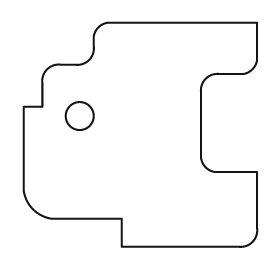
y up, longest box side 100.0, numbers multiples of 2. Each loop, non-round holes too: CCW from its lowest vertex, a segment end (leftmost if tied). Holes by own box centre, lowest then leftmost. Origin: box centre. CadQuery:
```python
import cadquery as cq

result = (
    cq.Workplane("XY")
    .moveTo(-8.0, -48.0)
    .lineTo(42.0, -48.0)
    .threePointArc((48.0, -46.0), (50.0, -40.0))
    .lineTo(50.0, -16.0)
    .lineTo(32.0, -16.0)
    .threePointArc((28.0, -14.0), (26.0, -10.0))
    .lineTo(26.0, 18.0)
    .threePointArc((28.0, 24.0), (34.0, 26.0))
    .lineTo(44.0, 26.0)
    .threePointArc((48.0, 28.0), (50.0, 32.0))
    .lineTo(50.0, 48.0)
    .lineTo(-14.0, 48.0)
    .threePointArc((-18.0, 46.0), (-20.0, 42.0))
    .lineTo(-20.0, 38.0)
    .threePointArc((-22.0, 32.0), (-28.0, 30.0))
    .lineTo(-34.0, 30.0)
    .threePointArc((-40.0, 28.0), (-42.0, 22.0))
    .lineTo(-42.0, 12.0)
    .lineTo(-50.0, 12.0)
    .lineTo(-50.0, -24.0)
    .threePointArc((-46.0, -32.0), (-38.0, -36.0))
    .lineTo(-8.0, -36.0)
    .close()
    .moveTo(-26.0, 8.0)
    .circle(6.0)
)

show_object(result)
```